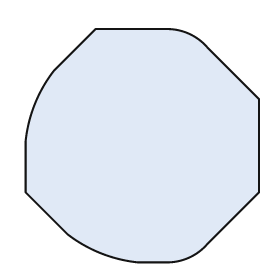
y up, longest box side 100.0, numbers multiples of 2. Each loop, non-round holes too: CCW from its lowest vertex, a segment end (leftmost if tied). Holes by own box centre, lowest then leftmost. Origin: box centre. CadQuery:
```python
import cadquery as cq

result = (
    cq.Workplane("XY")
    .moveTo(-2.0, -50.0)
    .lineTo(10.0, -50.0)
    .threePointArc((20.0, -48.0), (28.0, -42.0))
    .lineTo(50.0, -20.0)
    .lineTo(50.0, 20.0)
    .lineTo(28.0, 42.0)
    .threePointArc((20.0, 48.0), (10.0, 50.0))
    .lineTo(-20.0, 50.0)
    .lineTo(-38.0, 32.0)
    .threePointArc((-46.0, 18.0), (-50.0, 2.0))
    .lineTo(-50.0, -20.0)
    .lineTo(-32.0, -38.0)
    .threePointArc((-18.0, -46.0), (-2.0, -50.0))
    .close()
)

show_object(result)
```